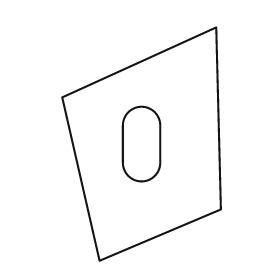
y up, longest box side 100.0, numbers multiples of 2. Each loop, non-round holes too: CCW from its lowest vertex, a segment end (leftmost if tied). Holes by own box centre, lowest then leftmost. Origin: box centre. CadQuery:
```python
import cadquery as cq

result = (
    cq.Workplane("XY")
    .moveTo(-18.0, -50.0)
    .lineTo(34.0, -28.0)
    .lineTo(32.0, 50.0)
    .lineTo(-34.0, 20.0)
    .close()
    .moveTo(-8.0, -8.0)
    .threePointArc((0.0, -16.0), (8.0, -8.0))
    .lineTo(8.0, 8.0)
    .threePointArc((0.0, 16.0), (-8.0, 8.0))
    .close()
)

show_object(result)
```